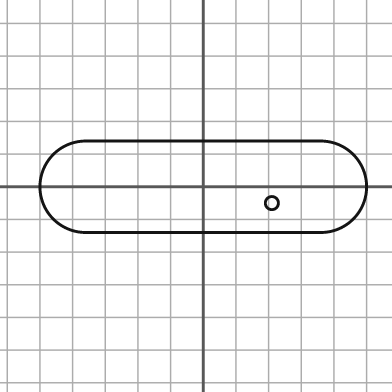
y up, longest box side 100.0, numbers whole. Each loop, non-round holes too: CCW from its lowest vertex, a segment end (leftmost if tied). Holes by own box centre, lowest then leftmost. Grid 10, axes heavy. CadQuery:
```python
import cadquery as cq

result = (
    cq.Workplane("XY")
    .moveTo(-36.0, -14.0)
    .lineTo(36.0, -14.0)
    .threePointArc((50.0, 0.0), (36.0, 14.0))
    .lineTo(-36.0, 14.0)
    .threePointArc((-50.0, 0.0), (-36.0, -14.0))
    .close()
    .moveTo(21.0, -5.0)
    .circle(2.0)
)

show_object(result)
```